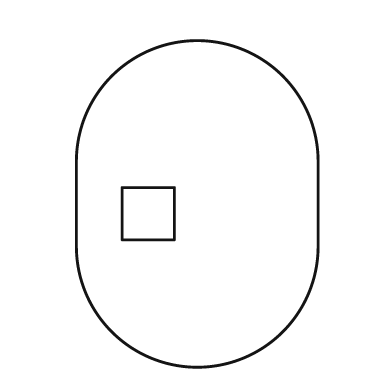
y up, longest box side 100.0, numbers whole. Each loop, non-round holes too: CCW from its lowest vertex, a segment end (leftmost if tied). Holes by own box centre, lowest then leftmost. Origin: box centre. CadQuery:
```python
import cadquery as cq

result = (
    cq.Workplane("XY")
    .moveTo(-37.0, -13.0)
    .threePointArc((0.0, -50.0), (37.0, -13.0))
    .lineTo(37.0, 13.0)
    .threePointArc((0.0, 50.0), (-37.0, 13.0))
    .close()
    .moveTo(-23.0, -11.0)
    .lineTo(-7.0, -11.0)
    .lineTo(-7.0, 5.0)
    .lineTo(-23.0, 5.0)
    .close()
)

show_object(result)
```